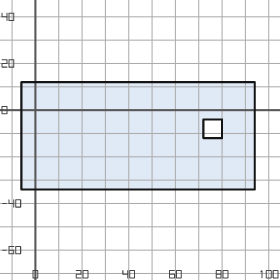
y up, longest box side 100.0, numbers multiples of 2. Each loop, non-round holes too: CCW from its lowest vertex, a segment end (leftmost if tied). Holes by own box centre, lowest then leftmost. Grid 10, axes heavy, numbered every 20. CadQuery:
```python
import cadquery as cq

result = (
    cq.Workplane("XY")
    .moveTo(-6.0, -34.0)
    .lineTo(94.0, -34.0)
    .lineTo(94.0, 12.0)
    .lineTo(-6.0, 12.0)
    .close()
    .moveTo(72.0, -12.0)
    .lineTo(80.0, -12.0)
    .lineTo(80.0, -4.0)
    .lineTo(72.0, -4.0)
    .close()
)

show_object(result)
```